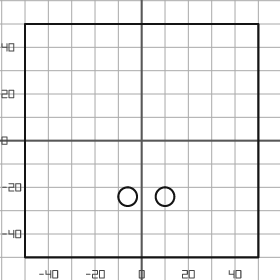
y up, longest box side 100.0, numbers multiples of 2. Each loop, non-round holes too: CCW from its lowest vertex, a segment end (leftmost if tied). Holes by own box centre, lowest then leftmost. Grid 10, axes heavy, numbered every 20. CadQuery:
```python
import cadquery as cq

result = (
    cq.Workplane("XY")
    .moveTo(-50.0, -50.0)
    .lineTo(50.0, -50.0)
    .lineTo(50.0, 50.0)
    .lineTo(-50.0, 50.0)
    .close()
    .moveTo(-6.0, -24.0)
    .circle(4.0)
    .moveTo(10.0, -24.0)
    .circle(4.0)
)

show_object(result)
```